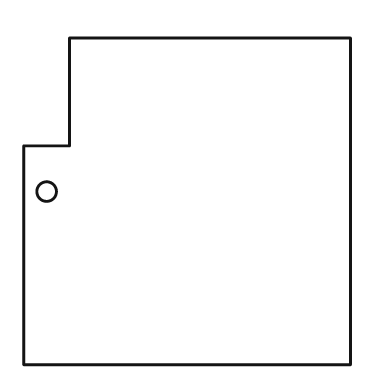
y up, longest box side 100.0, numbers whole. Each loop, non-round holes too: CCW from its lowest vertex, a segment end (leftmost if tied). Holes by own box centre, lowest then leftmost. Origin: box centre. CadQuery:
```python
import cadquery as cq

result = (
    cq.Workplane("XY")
    .moveTo(-50.0, -50.0)
    .lineTo(50.0, -50.0)
    .lineTo(50.0, 50.0)
    .lineTo(-36.0, 50.0)
    .lineTo(-36.0, 17.0)
    .lineTo(-50.0, 17.0)
    .close()
    .moveTo(-43.0, 3.0)
    .circle(3.0)
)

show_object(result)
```